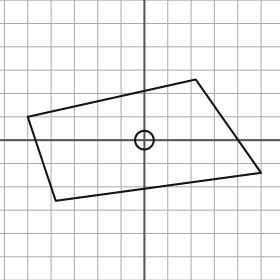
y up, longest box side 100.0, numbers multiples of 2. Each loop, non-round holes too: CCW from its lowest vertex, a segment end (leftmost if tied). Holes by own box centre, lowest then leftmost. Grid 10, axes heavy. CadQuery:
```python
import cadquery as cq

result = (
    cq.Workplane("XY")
    .moveTo(-38.0, -26.0)
    .lineTo(50.0, -14.0)
    .lineTo(22.0, 26.0)
    .lineTo(-50.0, 10.0)
    .close()
    .moveTo(0.0, 0.0)
    .circle(4.0)
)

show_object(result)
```